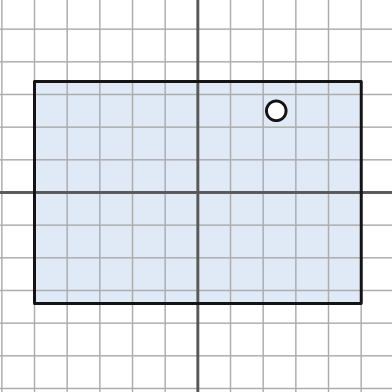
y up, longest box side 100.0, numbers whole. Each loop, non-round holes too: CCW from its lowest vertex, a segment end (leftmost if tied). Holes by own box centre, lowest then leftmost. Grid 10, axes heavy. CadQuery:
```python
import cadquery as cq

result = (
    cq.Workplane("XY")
    .moveTo(-50.0, -34.0)
    .lineTo(50.0, -34.0)
    .lineTo(50.0, 34.0)
    .lineTo(-50.0, 34.0)
    .close()
    .moveTo(24.0, 25.0)
    .circle(3.0)
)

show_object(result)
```